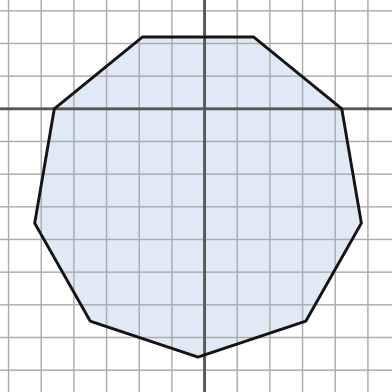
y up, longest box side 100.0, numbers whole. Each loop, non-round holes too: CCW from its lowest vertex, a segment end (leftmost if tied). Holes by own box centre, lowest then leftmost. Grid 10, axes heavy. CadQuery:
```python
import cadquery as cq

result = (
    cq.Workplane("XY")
    .moveTo(-2.0, -76.0)
    .lineTo(31.0, -65.0)
    .lineTo(48.0, -35.0)
    .lineTo(42.0, 0.0)
    .lineTo(15.0, 22.0)
    .lineTo(-19.0, 22.0)
    .lineTo(-46.0, 0.0)
    .lineTo(-52.0, -35.0)
    .lineTo(-35.0, -65.0)
    .close()
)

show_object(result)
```